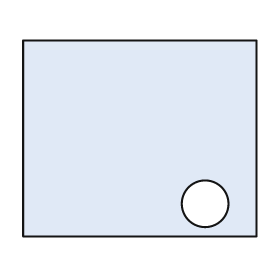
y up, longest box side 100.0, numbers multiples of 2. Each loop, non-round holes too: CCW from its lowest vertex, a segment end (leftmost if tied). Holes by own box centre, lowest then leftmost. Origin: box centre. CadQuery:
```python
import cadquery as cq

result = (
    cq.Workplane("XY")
    .moveTo(-50.0, -42.0)
    .lineTo(50.0, -42.0)
    .lineTo(50.0, 42.0)
    .lineTo(-50.0, 42.0)
    .close()
    .moveTo(28.0, -28.0)
    .circle(10.0)
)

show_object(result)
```